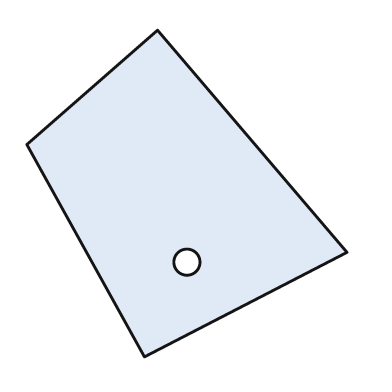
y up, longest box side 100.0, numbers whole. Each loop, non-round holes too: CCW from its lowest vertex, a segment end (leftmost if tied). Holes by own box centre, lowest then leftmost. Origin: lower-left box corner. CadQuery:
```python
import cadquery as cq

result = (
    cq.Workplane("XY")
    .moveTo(36.0, 0.0)
    .lineTo(98.0, 32.0)
    .lineTo(40.0, 100.0)
    .lineTo(0.0, 65.0)
    .close()
    .moveTo(49.0, 29.0)
    .circle(4.0)
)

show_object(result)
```